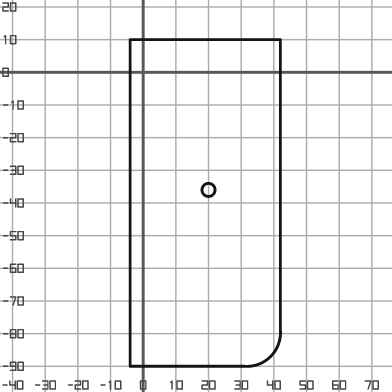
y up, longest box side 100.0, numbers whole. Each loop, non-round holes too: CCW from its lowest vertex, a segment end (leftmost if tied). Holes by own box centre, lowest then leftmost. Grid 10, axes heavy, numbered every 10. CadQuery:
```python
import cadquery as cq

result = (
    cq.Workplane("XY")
    .moveTo(-4.0, -90.0)
    .lineTo(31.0, -90.0)
    .threePointArc((39.0, -87.0), (42.0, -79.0))
    .lineTo(42.0, 10.0)
    .lineTo(-4.0, 10.0)
    .close()
    .moveTo(20.0, -36.0)
    .circle(2.0)
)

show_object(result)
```